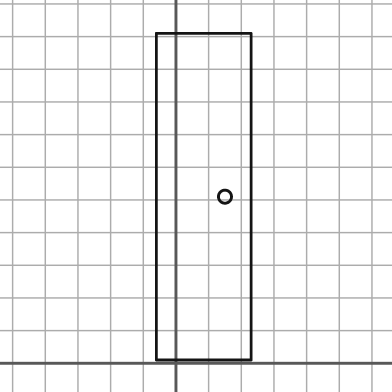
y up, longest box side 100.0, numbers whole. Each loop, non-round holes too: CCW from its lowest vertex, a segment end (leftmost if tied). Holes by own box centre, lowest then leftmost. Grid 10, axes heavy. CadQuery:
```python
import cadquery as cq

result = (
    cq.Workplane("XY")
    .moveTo(-6.0, 1.0)
    .lineTo(23.0, 1.0)
    .lineTo(23.0, 101.0)
    .lineTo(-6.0, 101.0)
    .close()
    .moveTo(15.0, 51.0)
    .circle(2.0)
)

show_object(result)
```